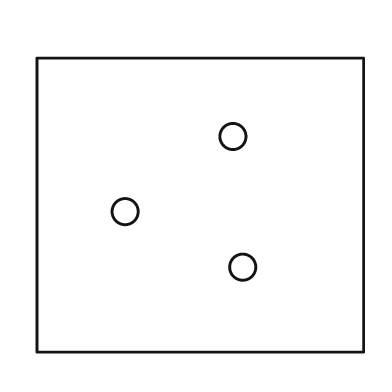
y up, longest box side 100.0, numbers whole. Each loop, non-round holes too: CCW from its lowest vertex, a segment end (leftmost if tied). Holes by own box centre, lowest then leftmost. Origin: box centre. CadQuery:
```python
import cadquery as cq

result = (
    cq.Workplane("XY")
    .moveTo(-50.0, -45.0)
    .lineTo(50.0, -45.0)
    .lineTo(50.0, 45.0)
    .lineTo(-50.0, 45.0)
    .close()
    .moveTo(13.0, -19.0)
    .circle(4.0)
    .moveTo(-23.0, -2.0)
    .circle(4.0)
    .moveTo(10.0, 21.0)
    .circle(4.0)
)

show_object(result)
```